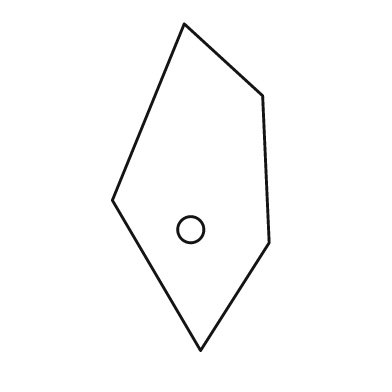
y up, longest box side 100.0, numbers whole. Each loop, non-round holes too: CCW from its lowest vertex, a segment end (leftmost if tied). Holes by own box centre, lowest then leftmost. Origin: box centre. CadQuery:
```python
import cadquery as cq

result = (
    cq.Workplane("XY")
    .moveTo(3.0, -50.0)
    .lineTo(24.0, -17.0)
    .lineTo(22.0, 28.0)
    .lineTo(-2.0, 50.0)
    .lineTo(-24.0, -4.0)
    .close()
    .moveTo(0.0, -13.0)
    .circle(4.0)
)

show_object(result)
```